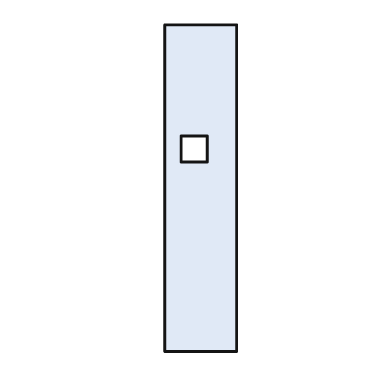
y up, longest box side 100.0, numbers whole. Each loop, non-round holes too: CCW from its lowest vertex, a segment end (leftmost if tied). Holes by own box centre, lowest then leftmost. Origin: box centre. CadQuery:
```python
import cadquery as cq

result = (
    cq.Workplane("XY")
    .moveTo(-11.0, -50.0)
    .lineTo(11.0, -50.0)
    .lineTo(11.0, 50.0)
    .lineTo(-11.0, 50.0)
    .close()
    .moveTo(-6.0, 8.0)
    .lineTo(2.0, 8.0)
    .lineTo(2.0, 16.0)
    .lineTo(-6.0, 16.0)
    .close()
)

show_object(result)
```